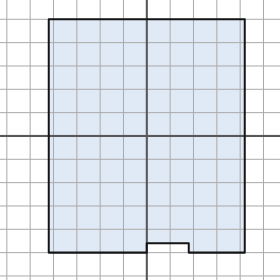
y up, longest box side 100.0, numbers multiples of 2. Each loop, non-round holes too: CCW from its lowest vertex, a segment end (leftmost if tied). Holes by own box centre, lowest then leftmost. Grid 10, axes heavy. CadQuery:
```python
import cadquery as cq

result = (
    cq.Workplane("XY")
    .moveTo(-42.0, -50.0)
    .lineTo(0.0, -50.0)
    .lineTo(0.0, -46.0)
    .lineTo(18.0, -46.0)
    .lineTo(18.0, -50.0)
    .lineTo(42.0, -50.0)
    .lineTo(42.0, 50.0)
    .lineTo(-42.0, 50.0)
    .close()
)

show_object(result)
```